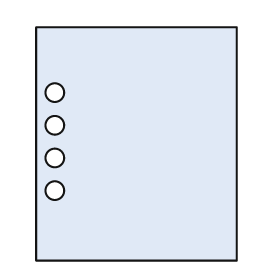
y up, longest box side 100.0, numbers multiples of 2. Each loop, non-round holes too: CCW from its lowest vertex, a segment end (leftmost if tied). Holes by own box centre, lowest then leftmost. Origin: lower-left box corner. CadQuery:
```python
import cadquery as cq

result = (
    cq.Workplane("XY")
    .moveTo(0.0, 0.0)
    .lineTo(86.0, 0.0)
    .lineTo(86.0, 100.0)
    .lineTo(0.0, 100.0)
    .close()
    .moveTo(8.0, 30.0)
    .circle(4.0)
    .moveTo(8.0, 44.0)
    .circle(4.0)
    .moveTo(8.0, 58.0)
    .circle(4.0)
    .moveTo(8.0, 72.0)
    .circle(4.0)
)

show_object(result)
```